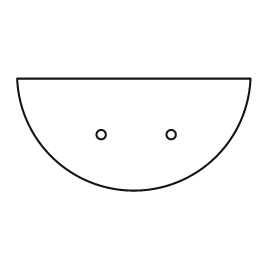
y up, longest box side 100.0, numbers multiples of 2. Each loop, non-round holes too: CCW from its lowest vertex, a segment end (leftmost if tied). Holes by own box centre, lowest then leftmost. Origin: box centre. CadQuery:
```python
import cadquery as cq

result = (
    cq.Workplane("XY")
    .moveTo(-50.0, 24.0)
    .threePointArc((0.0, -24.0), (50.0, 24.0))
    .close()
    .moveTo(-14.0, 0.0)
    .circle(2.0)
    .moveTo(16.0, 0.0)
    .circle(2.0)
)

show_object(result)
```